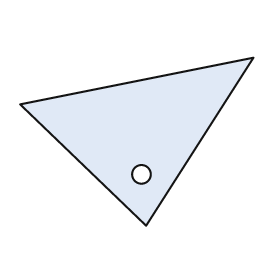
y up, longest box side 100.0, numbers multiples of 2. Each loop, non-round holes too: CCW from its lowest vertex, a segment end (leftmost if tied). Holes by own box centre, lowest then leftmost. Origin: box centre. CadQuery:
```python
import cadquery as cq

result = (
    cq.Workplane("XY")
    .moveTo(4.0, -36.0)
    .lineTo(50.0, 36.0)
    .lineTo(-50.0, 16.0)
    .close()
    .moveTo(2.0, -14.0)
    .circle(4.0)
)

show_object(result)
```